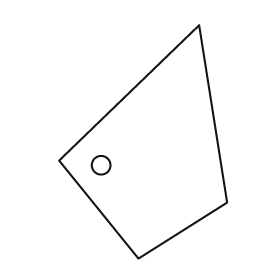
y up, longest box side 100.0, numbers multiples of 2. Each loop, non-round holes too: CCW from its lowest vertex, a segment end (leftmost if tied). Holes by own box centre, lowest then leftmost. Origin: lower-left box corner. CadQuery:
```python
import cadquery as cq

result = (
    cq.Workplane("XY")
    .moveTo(34.0, 0.0)
    .lineTo(72.0, 24.0)
    .lineTo(60.0, 100.0)
    .lineTo(0.0, 42.0)
    .close()
    .moveTo(18.0, 40.0)
    .circle(4.0)
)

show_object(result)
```